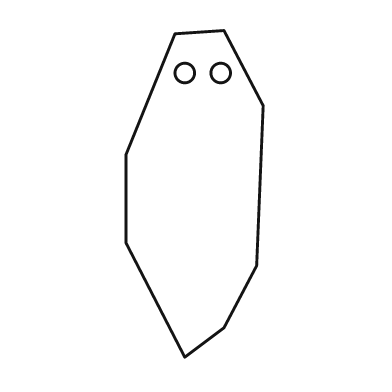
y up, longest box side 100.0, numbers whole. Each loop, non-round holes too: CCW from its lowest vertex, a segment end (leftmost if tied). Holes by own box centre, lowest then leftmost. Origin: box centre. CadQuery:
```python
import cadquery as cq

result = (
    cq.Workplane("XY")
    .moveTo(-3.0, -50.0)
    .lineTo(9.0, -41.0)
    .lineTo(19.0, -22.0)
    .lineTo(21.0, 27.0)
    .lineTo(9.0, 50.0)
    .lineTo(-6.0, 49.0)
    .lineTo(-21.0, 12.0)
    .lineTo(-21.0, -15.0)
    .close()
    .moveTo(-3.0, 37.0)
    .circle(3.0)
    .moveTo(8.0, 37.0)
    .circle(3.0)
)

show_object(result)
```